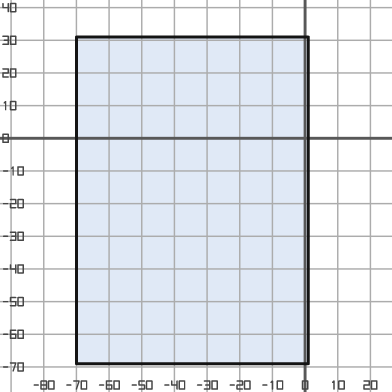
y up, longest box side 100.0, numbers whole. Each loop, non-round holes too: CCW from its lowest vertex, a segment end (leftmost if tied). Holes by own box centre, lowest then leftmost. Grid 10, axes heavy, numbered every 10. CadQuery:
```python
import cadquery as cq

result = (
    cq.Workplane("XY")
    .moveTo(-70.0, -69.0)
    .lineTo(1.0, -69.0)
    .lineTo(1.0, 31.0)
    .lineTo(-70.0, 31.0)
    .close()
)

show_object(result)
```